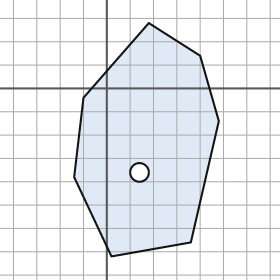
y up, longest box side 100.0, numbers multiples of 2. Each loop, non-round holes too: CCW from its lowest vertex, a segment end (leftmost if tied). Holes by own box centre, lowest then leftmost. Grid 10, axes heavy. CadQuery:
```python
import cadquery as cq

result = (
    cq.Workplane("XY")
    .moveTo(2.0, -72.0)
    .lineTo(36.0, -66.0)
    .lineTo(48.0, -14.0)
    .lineTo(40.0, 14.0)
    .lineTo(18.0, 28.0)
    .lineTo(-10.0, -4.0)
    .lineTo(-14.0, -38.0)
    .close()
    .moveTo(14.0, -36.0)
    .circle(4.0)
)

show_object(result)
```